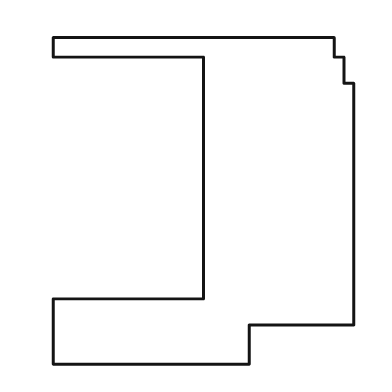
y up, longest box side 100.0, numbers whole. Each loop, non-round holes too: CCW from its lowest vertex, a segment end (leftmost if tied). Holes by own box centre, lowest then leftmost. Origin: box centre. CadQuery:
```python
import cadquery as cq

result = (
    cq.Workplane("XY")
    .moveTo(-46.0, -50.0)
    .lineTo(14.0, -50.0)
    .lineTo(14.0, -38.0)
    .lineTo(46.0, -38.0)
    .lineTo(46.0, 36.0)
    .lineTo(43.0, 36.0)
    .lineTo(43.0, 44.0)
    .lineTo(40.0, 44.0)
    .lineTo(40.0, 50.0)
    .lineTo(-46.0, 50.0)
    .lineTo(-46.0, 44.0)
    .lineTo(0.0, 44.0)
    .lineTo(0.0, -30.0)
    .lineTo(-46.0, -30.0)
    .close()
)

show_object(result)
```